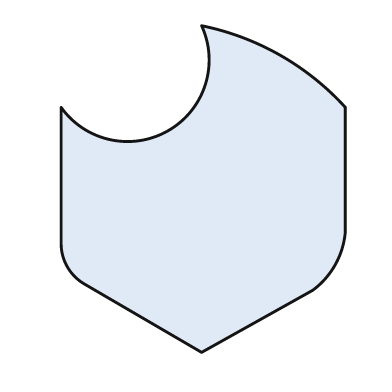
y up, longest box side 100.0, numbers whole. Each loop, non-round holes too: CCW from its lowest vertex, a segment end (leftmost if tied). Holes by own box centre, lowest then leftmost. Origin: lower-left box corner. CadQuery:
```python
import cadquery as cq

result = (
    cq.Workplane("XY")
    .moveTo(43.0, 0.0)
    .lineTo(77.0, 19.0)
    .threePointArc((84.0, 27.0), (87.0, 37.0))
    .lineTo(87.0, 75.0)
    .threePointArc((67.0, 91.0), (43.0, 100.0))
    .threePointArc((33.0, 68.0), (0.0, 75.0))
    .lineTo(0.0, 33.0)
    .threePointArc((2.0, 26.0), (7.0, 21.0))
    .close()
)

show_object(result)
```